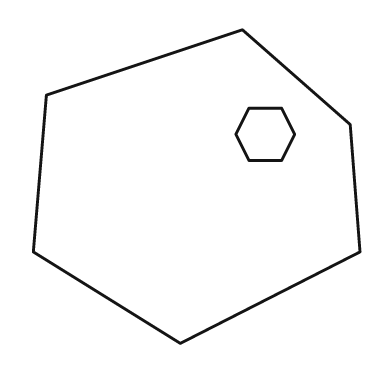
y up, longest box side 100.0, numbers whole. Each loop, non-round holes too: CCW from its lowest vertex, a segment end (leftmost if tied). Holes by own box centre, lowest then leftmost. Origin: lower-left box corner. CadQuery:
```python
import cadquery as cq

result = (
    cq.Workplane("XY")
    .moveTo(45.0, 0.0)
    .lineTo(100.0, 28.0)
    .lineTo(97.0, 67.0)
    .lineTo(64.0, 96.0)
    .lineTo(4.0, 76.0)
    .lineTo(0.0, 28.0)
    .close()
    .moveTo(66.0, 56.0)
    .lineTo(76.0, 56.0)
    .lineTo(80.0, 64.0)
    .lineTo(76.0, 72.0)
    .lineTo(66.0, 72.0)
    .lineTo(62.0, 64.0)
    .close()
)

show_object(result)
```